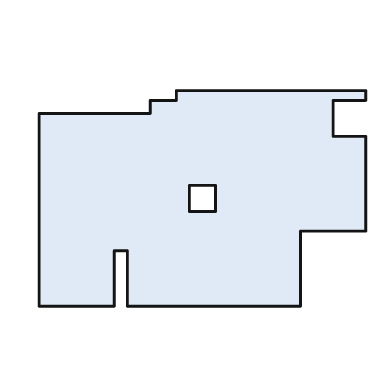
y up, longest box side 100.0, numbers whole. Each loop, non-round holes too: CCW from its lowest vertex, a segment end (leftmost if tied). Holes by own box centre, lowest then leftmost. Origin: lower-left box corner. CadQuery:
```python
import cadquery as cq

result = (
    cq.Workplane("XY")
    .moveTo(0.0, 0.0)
    .lineTo(23.0, 0.0)
    .lineTo(23.0, 17.0)
    .lineTo(27.0, 17.0)
    .lineTo(27.0, 0.0)
    .lineTo(80.0, 0.0)
    .lineTo(80.0, 23.0)
    .lineTo(100.0, 23.0)
    .lineTo(100.0, 52.0)
    .lineTo(90.0, 52.0)
    .lineTo(90.0, 63.0)
    .lineTo(100.0, 63.0)
    .lineTo(100.0, 66.0)
    .lineTo(42.0, 66.0)
    .lineTo(42.0, 63.0)
    .lineTo(34.0, 63.0)
    .lineTo(34.0, 59.0)
    .lineTo(0.0, 59.0)
    .close()
    .moveTo(46.0, 29.0)
    .lineTo(54.0, 29.0)
    .lineTo(54.0, 37.0)
    .lineTo(46.0, 37.0)
    .close()
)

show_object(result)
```